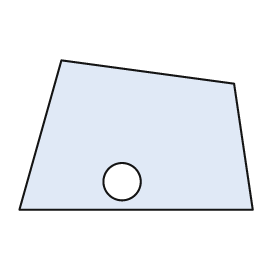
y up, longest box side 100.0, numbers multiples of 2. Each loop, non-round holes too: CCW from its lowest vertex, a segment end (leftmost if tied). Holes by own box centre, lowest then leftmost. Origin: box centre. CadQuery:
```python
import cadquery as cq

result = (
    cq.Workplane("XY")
    .moveTo(-50.0, -32.0)
    .lineTo(50.0, -32.0)
    .lineTo(42.0, 22.0)
    .lineTo(-32.0, 32.0)
    .close()
    .moveTo(-6.0, -20.0)
    .circle(8.0)
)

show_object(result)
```